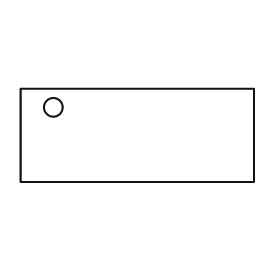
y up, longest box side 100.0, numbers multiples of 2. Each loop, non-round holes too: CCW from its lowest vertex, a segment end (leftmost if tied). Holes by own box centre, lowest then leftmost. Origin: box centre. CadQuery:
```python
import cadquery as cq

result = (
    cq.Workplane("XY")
    .moveTo(-50.0, -20.0)
    .lineTo(50.0, -20.0)
    .lineTo(50.0, 20.0)
    .lineTo(-50.0, 20.0)
    .close()
    .moveTo(-36.0, 12.0)
    .circle(4.0)
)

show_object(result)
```